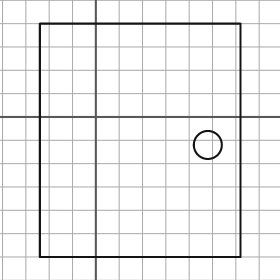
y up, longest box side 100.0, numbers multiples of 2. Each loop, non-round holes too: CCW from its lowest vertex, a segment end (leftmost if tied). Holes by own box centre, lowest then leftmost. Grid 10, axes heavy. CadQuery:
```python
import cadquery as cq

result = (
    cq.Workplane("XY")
    .moveTo(-24.0, -60.0)
    .lineTo(62.0, -60.0)
    .lineTo(62.0, 40.0)
    .lineTo(-24.0, 40.0)
    .close()
    .moveTo(48.0, -12.0)
    .circle(6.0)
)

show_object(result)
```